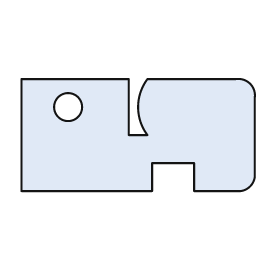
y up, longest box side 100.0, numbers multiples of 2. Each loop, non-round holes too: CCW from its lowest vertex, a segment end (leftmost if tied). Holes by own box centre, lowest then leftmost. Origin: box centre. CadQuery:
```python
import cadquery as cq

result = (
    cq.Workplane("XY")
    .moveTo(-50.0, -24.0)
    .lineTo(6.0, -24.0)
    .lineTo(6.0, -12.0)
    .lineTo(24.0, -12.0)
    .lineTo(24.0, -24.0)
    .lineTo(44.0, -24.0)
    .threePointArc((48.0, -22.0), (50.0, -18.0))
    .lineTo(50.0, 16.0)
    .threePointArc((48.0, 22.0), (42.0, 24.0))
    .lineTo(4.0, 24.0)
    .threePointArc((0.0, 12.0), (4.0, 0.0))
    .lineTo(-4.0, 0.0)
    .lineTo(-4.0, 24.0)
    .lineTo(-50.0, 24.0)
    .close()
    .moveTo(-30.0, 12.0)
    .circle(6.0)
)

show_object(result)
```